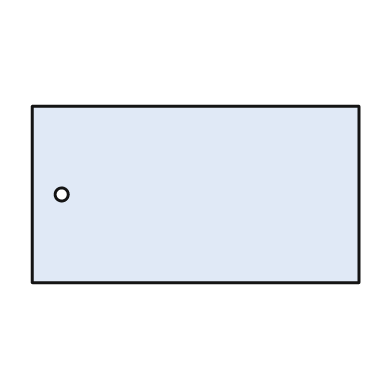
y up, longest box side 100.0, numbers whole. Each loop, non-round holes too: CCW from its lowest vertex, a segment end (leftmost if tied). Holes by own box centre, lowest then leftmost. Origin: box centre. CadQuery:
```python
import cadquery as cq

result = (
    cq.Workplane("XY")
    .moveTo(-50.0, -27.0)
    .lineTo(50.0, -27.0)
    .lineTo(50.0, 27.0)
    .lineTo(-50.0, 27.0)
    .close()
    .moveTo(-41.0, 0.0)
    .circle(2.0)
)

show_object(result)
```